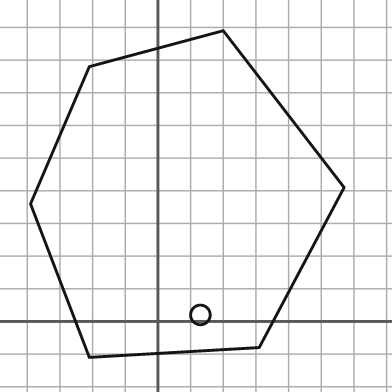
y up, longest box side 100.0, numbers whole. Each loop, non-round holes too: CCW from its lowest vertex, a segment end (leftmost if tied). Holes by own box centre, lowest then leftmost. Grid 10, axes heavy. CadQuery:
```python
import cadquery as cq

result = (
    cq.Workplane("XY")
    .moveTo(-21.0, -11.0)
    .lineTo(31.0, -8.0)
    .lineTo(57.0, 41.0)
    .lineTo(20.0, 89.0)
    .lineTo(-21.0, 78.0)
    .lineTo(-39.0, 36.0)
    .close()
    .moveTo(13.0, 2.0)
    .circle(3.0)
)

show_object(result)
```